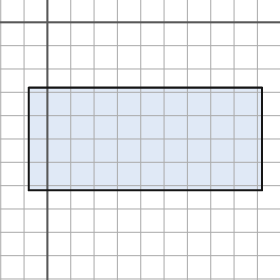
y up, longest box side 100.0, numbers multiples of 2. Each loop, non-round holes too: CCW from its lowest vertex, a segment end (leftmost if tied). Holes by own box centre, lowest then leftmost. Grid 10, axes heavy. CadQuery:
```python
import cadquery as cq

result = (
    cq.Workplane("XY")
    .moveTo(-8.0, -72.0)
    .lineTo(92.0, -72.0)
    .lineTo(92.0, -28.0)
    .lineTo(-8.0, -28.0)
    .close()
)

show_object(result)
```